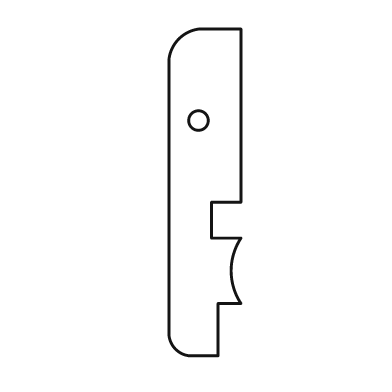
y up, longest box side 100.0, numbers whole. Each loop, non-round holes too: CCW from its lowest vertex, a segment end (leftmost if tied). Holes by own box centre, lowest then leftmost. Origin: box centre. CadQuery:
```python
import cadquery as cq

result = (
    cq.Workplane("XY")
    .moveTo(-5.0, -50.0)
    .lineTo(4.0, -50.0)
    .lineTo(4.0, -34.0)
    .lineTo(11.0, -34.0)
    .threePointArc((8.0, -24.0), (11.0, -14.0))
    .lineTo(2.0, -14.0)
    .lineTo(2.0, -3.0)
    .lineTo(11.0, -3.0)
    .lineTo(11.0, 50.0)
    .lineTo(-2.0, 50.0)
    .threePointArc((-8.0, 47.0), (-11.0, 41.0))
    .lineTo(-11.0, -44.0)
    .threePointArc((-9.0, -48.0), (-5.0, -50.0))
    .close()
    .moveTo(-2.0, 22.0)
    .circle(3.0)
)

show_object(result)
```